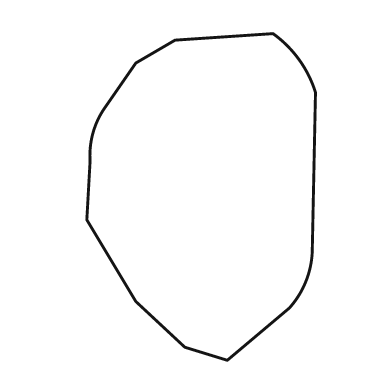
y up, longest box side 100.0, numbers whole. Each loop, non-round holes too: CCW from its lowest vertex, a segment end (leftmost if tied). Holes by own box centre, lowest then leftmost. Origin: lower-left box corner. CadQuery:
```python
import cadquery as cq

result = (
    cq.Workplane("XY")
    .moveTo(43.0, 0.0)
    .lineTo(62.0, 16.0)
    .threePointArc((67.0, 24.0), (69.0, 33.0))
    .lineTo(70.0, 82.0)
    .threePointArc((65.0, 92.0), (57.0, 100.0))
    .lineTo(27.0, 98.0)
    .lineTo(15.0, 91.0)
    .lineTo(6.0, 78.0)
    .threePointArc((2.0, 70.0), (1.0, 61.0))
    .lineTo(0.0, 43.0)
    .lineTo(15.0, 18.0)
    .lineTo(30.0, 4.0)
    .close()
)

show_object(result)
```